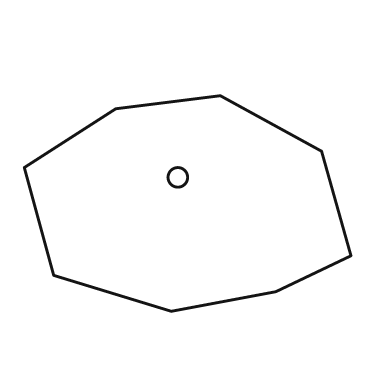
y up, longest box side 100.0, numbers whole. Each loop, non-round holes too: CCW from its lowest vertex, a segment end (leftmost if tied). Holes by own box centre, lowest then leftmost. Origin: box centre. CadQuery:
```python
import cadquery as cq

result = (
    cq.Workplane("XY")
    .moveTo(-5.0, -33.0)
    .lineTo(27.0, -27.0)
    .lineTo(50.0, -16.0)
    .lineTo(41.0, 16.0)
    .lineTo(10.0, 33.0)
    .lineTo(-22.0, 29.0)
    .lineTo(-50.0, 11.0)
    .lineTo(-41.0, -22.0)
    .close()
    .moveTo(-3.0, 8.0)
    .circle(3.0)
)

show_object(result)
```